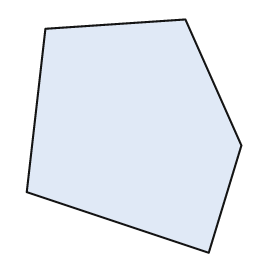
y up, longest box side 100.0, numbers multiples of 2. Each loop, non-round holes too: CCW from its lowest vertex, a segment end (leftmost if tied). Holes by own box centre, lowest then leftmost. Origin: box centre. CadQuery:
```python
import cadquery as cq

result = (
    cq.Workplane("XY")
    .moveTo(32.0, -50.0)
    .lineTo(46.0, -4.0)
    .lineTo(22.0, 50.0)
    .lineTo(-38.0, 46.0)
    .lineTo(-46.0, -24.0)
    .close()
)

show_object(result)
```